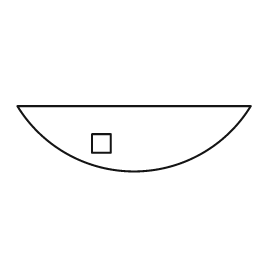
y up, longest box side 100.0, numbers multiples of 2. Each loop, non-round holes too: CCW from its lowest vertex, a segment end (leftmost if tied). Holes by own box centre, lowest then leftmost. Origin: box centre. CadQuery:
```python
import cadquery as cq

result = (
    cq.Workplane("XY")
    .moveTo(-50.0, 14.0)
    .threePointArc((0.0, -14.0), (50.0, 14.0))
    .close()
    .moveTo(-18.0, -6.0)
    .lineTo(-10.0, -6.0)
    .lineTo(-10.0, 2.0)
    .lineTo(-18.0, 2.0)
    .close()
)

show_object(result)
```